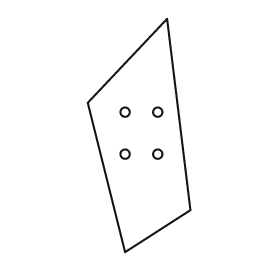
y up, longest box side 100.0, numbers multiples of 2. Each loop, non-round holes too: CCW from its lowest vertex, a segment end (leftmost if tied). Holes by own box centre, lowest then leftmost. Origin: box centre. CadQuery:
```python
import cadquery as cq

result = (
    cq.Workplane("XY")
    .moveTo(-6.0, -50.0)
    .lineTo(22.0, -32.0)
    .lineTo(12.0, 50.0)
    .lineTo(-22.0, 14.0)
    .close()
    .moveTo(-6.0, -8.0)
    .circle(2.0)
    .moveTo(8.0, -8.0)
    .circle(2.0)
    .moveTo(-6.0, 10.0)
    .circle(2.0)
    .moveTo(8.0, 10.0)
    .circle(2.0)
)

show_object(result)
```